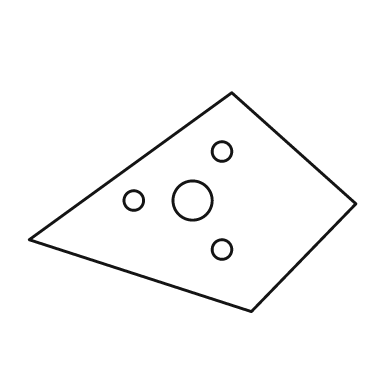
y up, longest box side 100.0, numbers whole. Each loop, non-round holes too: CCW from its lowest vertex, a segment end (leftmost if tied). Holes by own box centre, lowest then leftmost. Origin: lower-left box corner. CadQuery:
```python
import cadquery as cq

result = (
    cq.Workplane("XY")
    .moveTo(68.0, 0.0)
    .lineTo(100.0, 33.0)
    .lineTo(62.0, 67.0)
    .lineTo(0.0, 22.0)
    .close()
    .moveTo(59.0, 19.0)
    .circle(3.0)
    .moveTo(32.0, 34.0)
    .circle(3.0)
    .moveTo(50.0, 34.0)
    .circle(6.0)
    .moveTo(59.0, 49.0)
    .circle(3.0)
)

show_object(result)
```